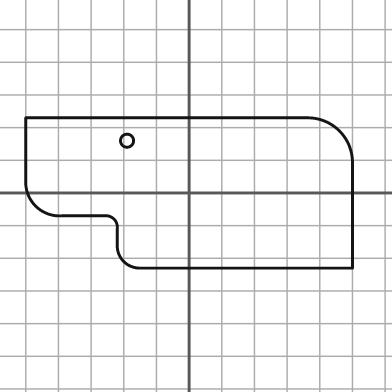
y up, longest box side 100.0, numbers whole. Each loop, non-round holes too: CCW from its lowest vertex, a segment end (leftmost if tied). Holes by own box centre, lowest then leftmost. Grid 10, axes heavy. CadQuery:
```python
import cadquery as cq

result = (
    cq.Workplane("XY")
    .moveTo(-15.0, -23.0)
    .lineTo(50.0, -23.0)
    .lineTo(50.0, 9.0)
    .threePointArc((46.0, 19.0), (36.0, 23.0))
    .lineTo(-50.0, 23.0)
    .lineTo(-50.0, 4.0)
    .threePointArc((-47.0, -4.0), (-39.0, -7.0))
    .lineTo(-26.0, -7.0)
    .threePointArc((-23.0, -8.0), (-22.0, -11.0))
    .lineTo(-22.0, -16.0)
    .threePointArc((-20.0, -21.0), (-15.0, -23.0))
    .close()
    .moveTo(-19.0, 16.0)
    .circle(2.0)
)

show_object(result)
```